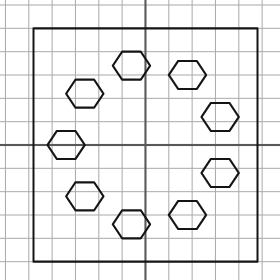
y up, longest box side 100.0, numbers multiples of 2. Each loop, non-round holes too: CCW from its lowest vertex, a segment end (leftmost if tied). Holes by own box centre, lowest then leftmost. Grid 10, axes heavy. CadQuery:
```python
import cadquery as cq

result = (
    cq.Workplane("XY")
    .moveTo(-48.0, -50.0)
    .lineTo(48.0, -50.0)
    .lineTo(48.0, 50.0)
    .lineTo(-48.0, 50.0)
    .close()
    .moveTo(-10.0, -40.0)
    .lineTo(-2.0, -40.0)
    .lineTo(2.0, -34.0)
    .lineTo(-2.0, -28.0)
    .lineTo(-10.0, -28.0)
    .lineTo(-14.0, -34.0)
    .close()
    .moveTo(14.0, -36.0)
    .lineTo(22.0, -36.0)
    .lineTo(26.0, -30.0)
    .lineTo(22.0, -24.0)
    .lineTo(14.0, -24.0)
    .lineTo(10.0, -30.0)
    .close()
    .moveTo(-30.0, -28.0)
    .lineTo(-22.0, -28.0)
    .lineTo(-18.0, -22.0)
    .lineTo(-22.0, -16.0)
    .lineTo(-30.0, -16.0)
    .lineTo(-34.0, -22.0)
    .close()
    .moveTo(28.0, -18.0)
    .lineTo(36.0, -18.0)
    .lineTo(40.0, -12.0)
    .lineTo(36.0, -6.0)
    .lineTo(28.0, -6.0)
    .lineTo(24.0, -12.0)
    .close()
    .moveTo(-38.0, -6.0)
    .lineTo(-30.0, -6.0)
    .lineTo(-26.0, 0.0)
    .lineTo(-30.0, 6.0)
    .lineTo(-38.0, 6.0)
    .lineTo(-42.0, 0.0)
    .close()
    .moveTo(28.0, 6.0)
    .lineTo(36.0, 6.0)
    .lineTo(40.0, 12.0)
    .lineTo(36.0, 18.0)
    .lineTo(28.0, 18.0)
    .lineTo(24.0, 12.0)
    .close()
    .moveTo(-30.0, 16.0)
    .lineTo(-22.0, 16.0)
    .lineTo(-18.0, 22.0)
    .lineTo(-22.0, 28.0)
    .lineTo(-30.0, 28.0)
    .lineTo(-34.0, 22.0)
    .close()
    .moveTo(14.0, 24.0)
    .lineTo(22.0, 24.0)
    .lineTo(26.0, 30.0)
    .lineTo(22.0, 36.0)
    .lineTo(14.0, 36.0)
    .lineTo(10.0, 30.0)
    .close()
    .moveTo(-10.0, 28.0)
    .lineTo(-2.0, 28.0)
    .lineTo(2.0, 34.0)
    .lineTo(-2.0, 40.0)
    .lineTo(-10.0, 40.0)
    .lineTo(-14.0, 34.0)
    .close()
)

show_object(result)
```